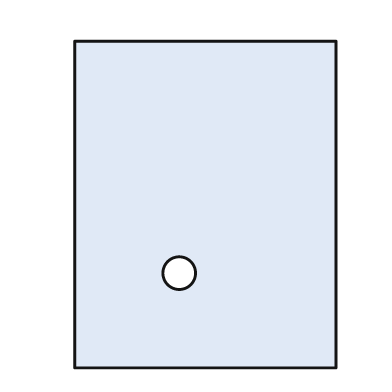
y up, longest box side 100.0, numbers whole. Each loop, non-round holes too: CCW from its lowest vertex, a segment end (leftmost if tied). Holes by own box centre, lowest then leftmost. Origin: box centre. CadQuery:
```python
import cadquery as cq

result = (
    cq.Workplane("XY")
    .moveTo(-40.0, -50.0)
    .lineTo(40.0, -50.0)
    .lineTo(40.0, 50.0)
    .lineTo(-40.0, 50.0)
    .close()
    .moveTo(-8.0, -21.0)
    .circle(5.0)
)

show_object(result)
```